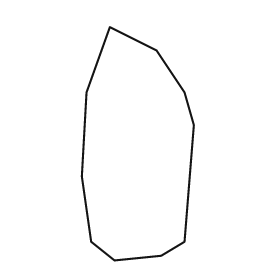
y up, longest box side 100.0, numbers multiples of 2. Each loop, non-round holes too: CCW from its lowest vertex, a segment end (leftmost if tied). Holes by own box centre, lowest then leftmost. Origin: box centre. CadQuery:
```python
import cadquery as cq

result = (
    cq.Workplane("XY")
    .moveTo(-10.0, -50.0)
    .lineTo(10.0, -48.0)
    .lineTo(20.0, -42.0)
    .lineTo(24.0, 8.0)
    .lineTo(20.0, 22.0)
    .lineTo(8.0, 40.0)
    .lineTo(-12.0, 50.0)
    .lineTo(-22.0, 22.0)
    .lineTo(-24.0, -14.0)
    .lineTo(-20.0, -42.0)
    .close()
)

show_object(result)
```